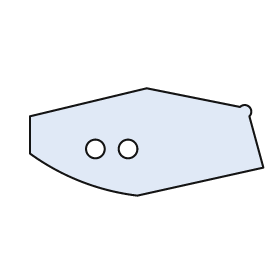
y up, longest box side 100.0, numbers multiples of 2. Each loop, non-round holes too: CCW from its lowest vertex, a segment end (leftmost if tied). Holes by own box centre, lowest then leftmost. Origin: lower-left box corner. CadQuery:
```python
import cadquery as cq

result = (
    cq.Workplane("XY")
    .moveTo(46.0, 0.0)
    .lineTo(100.0, 12.0)
    .lineTo(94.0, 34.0)
    .threePointArc((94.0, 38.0), (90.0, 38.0))
    .lineTo(50.0, 46.0)
    .lineTo(0.0, 34.0)
    .lineTo(0.0, 18.0)
    .threePointArc((22.0, 6.0), (46.0, 0.0))
    .close()
    .moveTo(28.0, 20.0)
    .circle(4.0)
    .moveTo(42.0, 20.0)
    .circle(4.0)
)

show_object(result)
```